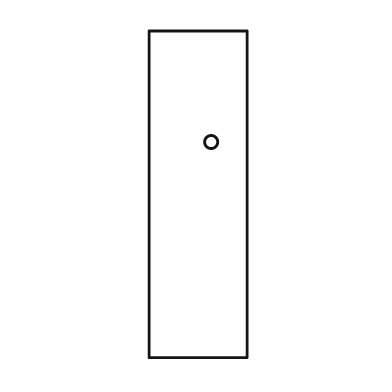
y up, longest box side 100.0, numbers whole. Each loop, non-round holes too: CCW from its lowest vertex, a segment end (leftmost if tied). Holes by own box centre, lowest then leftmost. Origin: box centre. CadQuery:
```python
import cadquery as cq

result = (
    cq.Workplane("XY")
    .moveTo(-15.0, -50.0)
    .lineTo(15.0, -50.0)
    .lineTo(15.0, 50.0)
    .lineTo(-15.0, 50.0)
    .close()
    .moveTo(4.0, 16.0)
    .circle(2.0)
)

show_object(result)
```